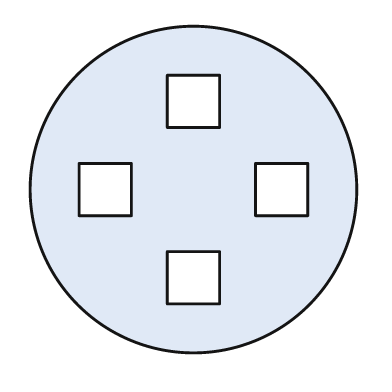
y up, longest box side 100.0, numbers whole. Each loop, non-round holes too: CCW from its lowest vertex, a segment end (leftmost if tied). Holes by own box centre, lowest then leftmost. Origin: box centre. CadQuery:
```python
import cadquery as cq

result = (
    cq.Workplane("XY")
    .moveTo(0.0, 0.0)
    .circle(50.0)
    .moveTo(-8.0, -35.0)
    .lineTo(8.0, -35.0)
    .lineTo(8.0, -19.0)
    .lineTo(-8.0, -19.0)
    .close()
    .moveTo(-35.0, -8.0)
    .lineTo(-19.0, -8.0)
    .lineTo(-19.0, 8.0)
    .lineTo(-35.0, 8.0)
    .close()
    .moveTo(19.0, -8.0)
    .lineTo(35.0, -8.0)
    .lineTo(35.0, 8.0)
    .lineTo(19.0, 8.0)
    .close()
    .moveTo(-8.0, 19.0)
    .lineTo(8.0, 19.0)
    .lineTo(8.0, 35.0)
    .lineTo(-8.0, 35.0)
    .close()
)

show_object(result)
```